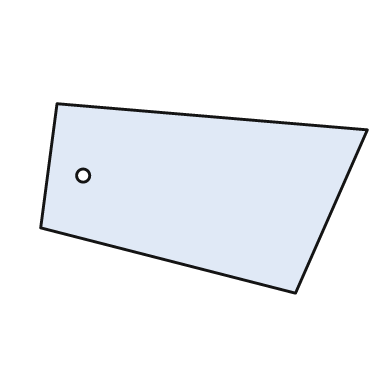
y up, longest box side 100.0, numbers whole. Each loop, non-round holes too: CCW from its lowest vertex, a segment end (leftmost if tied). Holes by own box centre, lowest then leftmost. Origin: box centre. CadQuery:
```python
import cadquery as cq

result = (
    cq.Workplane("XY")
    .moveTo(28.0, -29.0)
    .lineTo(50.0, 21.0)
    .lineTo(-45.0, 29.0)
    .lineTo(-50.0, -9.0)
    .close()
    .moveTo(-37.0, 7.0)
    .circle(2.0)
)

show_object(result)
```